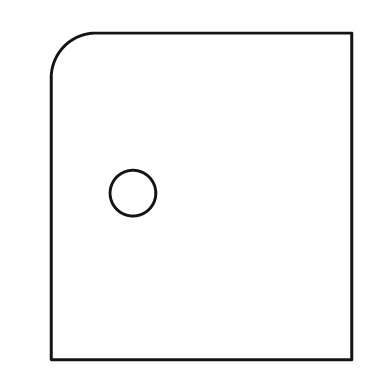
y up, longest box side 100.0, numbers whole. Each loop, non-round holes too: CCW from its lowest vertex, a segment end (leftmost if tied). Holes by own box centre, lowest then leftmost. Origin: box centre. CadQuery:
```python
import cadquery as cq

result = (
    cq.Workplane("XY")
    .moveTo(-46.0, -50.0)
    .lineTo(46.0, -50.0)
    .lineTo(46.0, 50.0)
    .lineTo(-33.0, 50.0)
    .threePointArc((-42.0, 46.0), (-46.0, 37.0))
    .close()
    .moveTo(-21.0, 1.0)
    .circle(7.0)
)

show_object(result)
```